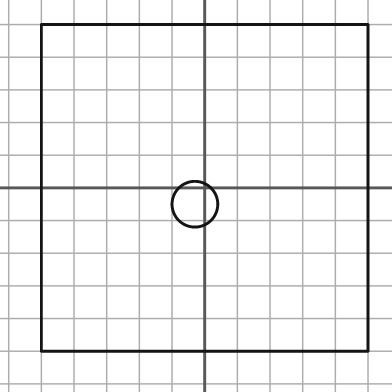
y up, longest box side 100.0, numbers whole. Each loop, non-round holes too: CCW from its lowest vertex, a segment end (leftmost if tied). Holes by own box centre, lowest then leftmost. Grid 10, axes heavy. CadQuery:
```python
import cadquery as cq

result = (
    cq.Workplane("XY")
    .moveTo(-50.0, -50.0)
    .lineTo(50.0, -50.0)
    .lineTo(50.0, 50.0)
    .lineTo(-50.0, 50.0)
    .close()
    .moveTo(-3.0, -5.0)
    .circle(7.0)
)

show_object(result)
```